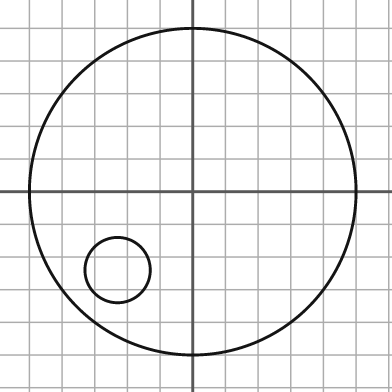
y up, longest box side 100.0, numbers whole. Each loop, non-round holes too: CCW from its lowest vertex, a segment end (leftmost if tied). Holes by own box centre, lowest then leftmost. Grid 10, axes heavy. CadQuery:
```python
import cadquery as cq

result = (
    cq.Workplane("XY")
    .moveTo(0.0, 0.0)
    .circle(50.0)
    .moveTo(-23.0, -24.0)
    .circle(10.0)
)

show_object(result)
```